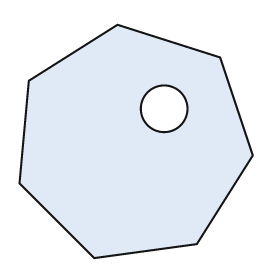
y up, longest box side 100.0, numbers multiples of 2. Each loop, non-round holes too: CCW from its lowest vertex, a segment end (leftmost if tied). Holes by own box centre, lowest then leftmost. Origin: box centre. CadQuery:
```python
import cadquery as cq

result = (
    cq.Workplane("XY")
    .moveTo(-18.0, -50.0)
    .lineTo(26.0, -44.0)
    .lineTo(50.0, -6.0)
    .lineTo(36.0, 36.0)
    .lineTo(-8.0, 50.0)
    .lineTo(-46.0, 26.0)
    .lineTo(-50.0, -18.0)
    .close()
    .moveTo(12.0, 14.0)
    .circle(10.0)
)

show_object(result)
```